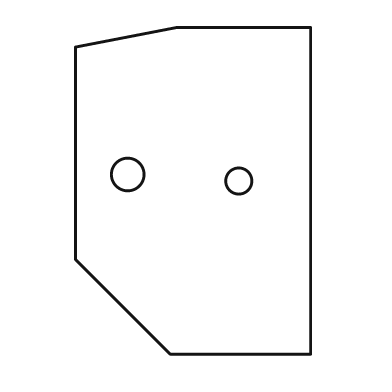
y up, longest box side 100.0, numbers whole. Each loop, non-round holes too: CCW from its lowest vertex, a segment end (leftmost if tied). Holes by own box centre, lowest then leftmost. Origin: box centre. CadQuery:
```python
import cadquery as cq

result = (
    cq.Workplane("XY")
    .moveTo(-7.0, -50.0)
    .lineTo(36.0, -50.0)
    .lineTo(36.0, 50.0)
    .lineTo(-5.0, 50.0)
    .lineTo(-36.0, 44.0)
    .lineTo(-36.0, -21.0)
    .close()
    .moveTo(14.0, 3.0)
    .circle(4.0)
    .moveTo(-20.0, 5.0)
    .circle(5.0)
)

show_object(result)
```